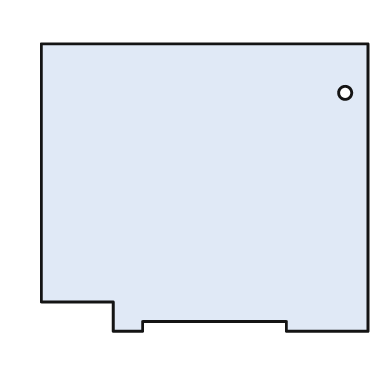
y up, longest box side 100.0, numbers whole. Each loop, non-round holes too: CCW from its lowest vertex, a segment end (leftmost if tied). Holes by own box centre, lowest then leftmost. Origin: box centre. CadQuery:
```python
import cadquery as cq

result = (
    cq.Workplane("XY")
    .moveTo(-28.0, -44.0)
    .lineTo(-19.0, -44.0)
    .lineTo(-19.0, -41.0)
    .lineTo(25.0, -41.0)
    .lineTo(25.0, -44.0)
    .lineTo(50.0, -44.0)
    .lineTo(50.0, 44.0)
    .lineTo(-50.0, 44.0)
    .lineTo(-50.0, -35.0)
    .lineTo(-28.0, -35.0)
    .close()
    .moveTo(43.0, 29.0)
    .circle(2.0)
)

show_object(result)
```